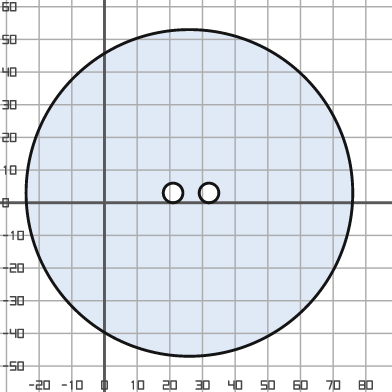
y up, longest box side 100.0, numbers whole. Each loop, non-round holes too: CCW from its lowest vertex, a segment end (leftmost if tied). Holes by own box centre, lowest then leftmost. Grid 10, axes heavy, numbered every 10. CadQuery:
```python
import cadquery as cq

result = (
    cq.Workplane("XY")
    .moveTo(26.0, 3.0)
    .circle(50.0)
    .moveTo(21.0, 3.0)
    .circle(3.0)
    .moveTo(32.0, 3.0)
    .circle(3.0)
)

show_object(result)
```